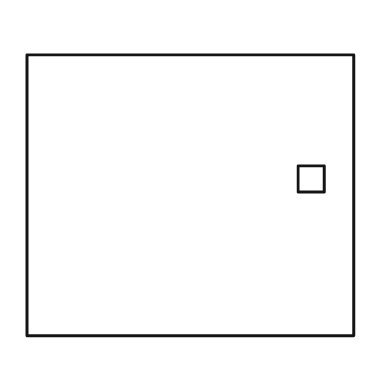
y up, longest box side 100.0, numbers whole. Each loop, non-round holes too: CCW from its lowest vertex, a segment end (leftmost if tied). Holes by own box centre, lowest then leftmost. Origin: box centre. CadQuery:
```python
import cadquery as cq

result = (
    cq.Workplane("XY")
    .moveTo(-50.0, -43.0)
    .lineTo(50.0, -43.0)
    .lineTo(50.0, 43.0)
    .lineTo(-50.0, 43.0)
    .close()
    .moveTo(33.0, 1.0)
    .lineTo(41.0, 1.0)
    .lineTo(41.0, 9.0)
    .lineTo(33.0, 9.0)
    .close()
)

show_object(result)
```